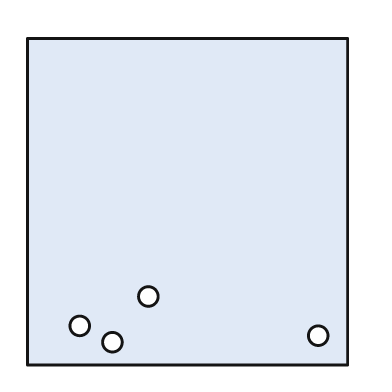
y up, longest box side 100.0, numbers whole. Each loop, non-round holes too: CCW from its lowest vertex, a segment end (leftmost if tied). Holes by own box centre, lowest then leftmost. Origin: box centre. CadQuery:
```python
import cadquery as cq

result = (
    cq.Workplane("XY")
    .moveTo(-49.0, -50.0)
    .lineTo(49.0, -50.0)
    .lineTo(49.0, 50.0)
    .lineTo(-49.0, 50.0)
    .close()
    .moveTo(-23.0, -43.0)
    .circle(3.0)
    .moveTo(40.0, -41.0)
    .circle(3.0)
    .moveTo(-33.0, -38.0)
    .circle(3.0)
    .moveTo(-12.0, -29.0)
    .circle(3.0)
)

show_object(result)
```